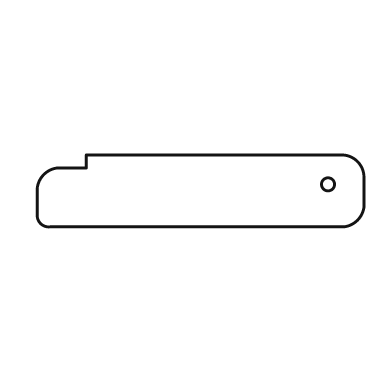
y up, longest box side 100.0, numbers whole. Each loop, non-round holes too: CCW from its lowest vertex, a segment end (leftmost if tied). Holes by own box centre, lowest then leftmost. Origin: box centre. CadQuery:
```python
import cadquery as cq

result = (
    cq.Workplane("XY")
    .moveTo(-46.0, -11.0)
    .lineTo(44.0, -11.0)
    .threePointArc((48.0, -9.0), (50.0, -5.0))
    .lineTo(50.0, 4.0)
    .threePointArc((48.0, 9.0), (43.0, 11.0))
    .lineTo(-35.0, 11.0)
    .lineTo(-35.0, 7.0)
    .lineTo(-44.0, 7.0)
    .threePointArc((-48.0, 5.0), (-50.0, 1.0))
    .lineTo(-50.0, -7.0)
    .threePointArc((-49.0, -10.0), (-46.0, -11.0))
    .close()
    .moveTo(39.0, 2.0)
    .circle(2.0)
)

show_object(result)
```